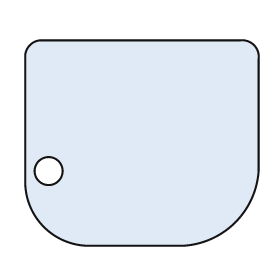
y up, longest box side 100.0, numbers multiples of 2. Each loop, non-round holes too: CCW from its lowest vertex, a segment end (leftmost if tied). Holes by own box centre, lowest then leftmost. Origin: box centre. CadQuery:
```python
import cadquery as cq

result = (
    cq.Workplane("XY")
    .moveTo(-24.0, -44.0)
    .lineTo(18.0, -44.0)
    .threePointArc((40.0, -34.0), (50.0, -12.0))
    .lineTo(50.0, 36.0)
    .threePointArc((48.0, 42.0), (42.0, 44.0))
    .lineTo(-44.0, 44.0)
    .threePointArc((-48.0, 42.0), (-50.0, 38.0))
    .lineTo(-50.0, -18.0)
    .threePointArc((-42.0, -36.0), (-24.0, -44.0))
    .close()
    .moveTo(-40.0, -12.0)
    .circle(6.0)
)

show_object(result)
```